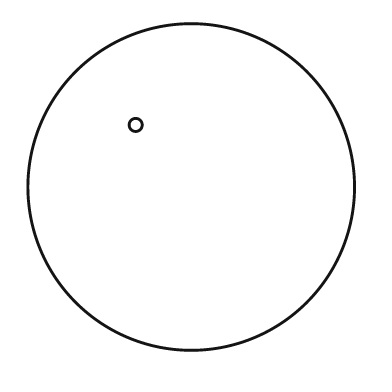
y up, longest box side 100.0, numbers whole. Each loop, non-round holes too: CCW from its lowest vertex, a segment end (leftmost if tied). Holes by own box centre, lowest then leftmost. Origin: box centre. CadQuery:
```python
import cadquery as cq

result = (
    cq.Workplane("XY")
    .moveTo(0.0, 0.0)
    .circle(50.0)
    .moveTo(-17.0, 19.0)
    .circle(2.0)
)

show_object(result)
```